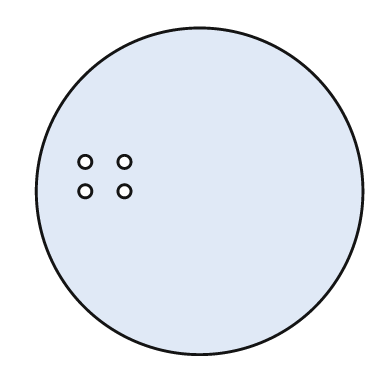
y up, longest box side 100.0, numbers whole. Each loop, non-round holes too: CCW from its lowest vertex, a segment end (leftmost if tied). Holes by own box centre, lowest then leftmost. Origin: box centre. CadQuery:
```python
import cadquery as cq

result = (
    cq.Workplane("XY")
    .moveTo(0.0, 0.0)
    .circle(50.0)
    .moveTo(-35.0, 0.0)
    .circle(2.0)
    .moveTo(-23.0, 0.0)
    .circle(2.0)
    .moveTo(-35.0, 9.0)
    .circle(2.0)
    .moveTo(-23.0, 9.0)
    .circle(2.0)
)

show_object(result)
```